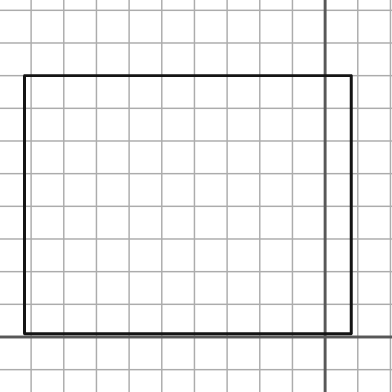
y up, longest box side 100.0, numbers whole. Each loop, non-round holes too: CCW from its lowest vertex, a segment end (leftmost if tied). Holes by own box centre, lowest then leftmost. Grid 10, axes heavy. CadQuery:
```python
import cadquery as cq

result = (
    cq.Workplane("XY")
    .moveTo(-92.0, 1.0)
    .lineTo(8.0, 1.0)
    .lineTo(8.0, 80.0)
    .lineTo(-92.0, 80.0)
    .close()
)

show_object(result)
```